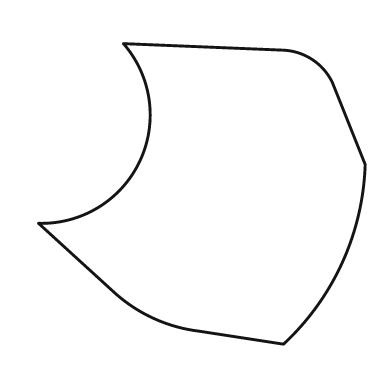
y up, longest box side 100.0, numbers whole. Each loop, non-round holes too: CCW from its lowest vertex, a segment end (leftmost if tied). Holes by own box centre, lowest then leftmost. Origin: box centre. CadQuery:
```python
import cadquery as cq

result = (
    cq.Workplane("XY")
    .moveTo(25.0, -46.0)
    .threePointArc((43.0, -21.0), (50.0, 9.0))
    .lineTo(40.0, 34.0)
    .threePointArc((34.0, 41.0), (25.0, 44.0))
    .lineTo(-24.0, 46.0)
    .threePointArc((-19.0, 10.0), (-50.0, -9.0))
    .lineTo(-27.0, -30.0)
    .threePointArc((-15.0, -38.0), (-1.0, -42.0))
    .close()
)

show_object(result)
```